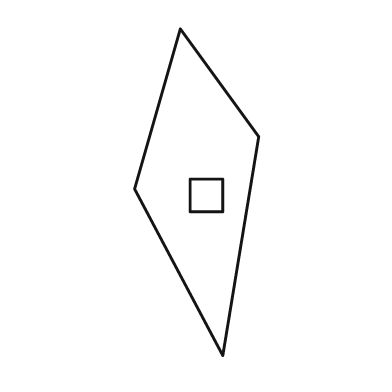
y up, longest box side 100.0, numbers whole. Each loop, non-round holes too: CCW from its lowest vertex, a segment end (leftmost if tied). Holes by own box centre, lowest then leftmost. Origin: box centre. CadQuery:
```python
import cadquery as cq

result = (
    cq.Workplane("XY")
    .moveTo(8.0, -50.0)
    .lineTo(19.0, 17.0)
    .lineTo(-5.0, 50.0)
    .lineTo(-19.0, 1.0)
    .close()
    .moveTo(-2.0, -6.0)
    .lineTo(8.0, -6.0)
    .lineTo(8.0, 4.0)
    .lineTo(-2.0, 4.0)
    .close()
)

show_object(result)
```